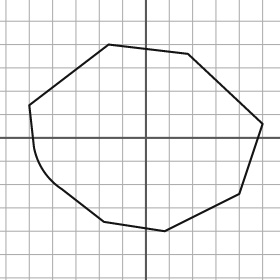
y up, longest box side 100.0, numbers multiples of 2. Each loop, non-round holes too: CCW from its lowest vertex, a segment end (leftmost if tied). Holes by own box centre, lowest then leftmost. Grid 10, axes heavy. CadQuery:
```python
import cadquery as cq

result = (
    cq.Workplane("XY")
    .moveTo(8.0, -40.0)
    .lineTo(40.0, -24.0)
    .lineTo(50.0, 6.0)
    .lineTo(18.0, 36.0)
    .lineTo(-16.0, 40.0)
    .lineTo(-50.0, 14.0)
    .lineTo(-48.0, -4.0)
    .threePointArc((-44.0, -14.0), (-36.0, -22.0))
    .lineTo(-18.0, -36.0)
    .close()
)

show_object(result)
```